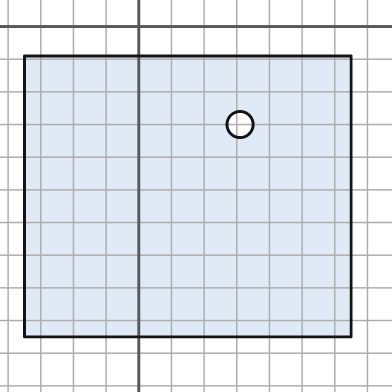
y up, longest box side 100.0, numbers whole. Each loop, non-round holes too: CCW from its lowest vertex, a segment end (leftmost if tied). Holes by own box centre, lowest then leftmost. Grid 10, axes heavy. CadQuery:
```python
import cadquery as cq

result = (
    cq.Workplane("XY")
    .moveTo(-35.0, -95.0)
    .lineTo(65.0, -95.0)
    .lineTo(65.0, -9.0)
    .lineTo(-35.0, -9.0)
    .close()
    .moveTo(31.0, -30.0)
    .circle(4.0)
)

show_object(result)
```